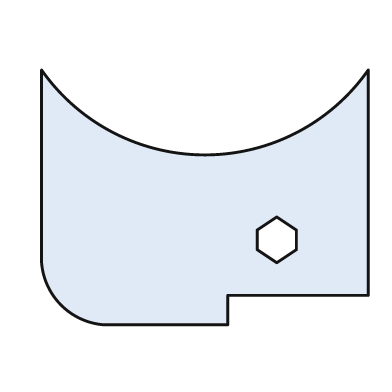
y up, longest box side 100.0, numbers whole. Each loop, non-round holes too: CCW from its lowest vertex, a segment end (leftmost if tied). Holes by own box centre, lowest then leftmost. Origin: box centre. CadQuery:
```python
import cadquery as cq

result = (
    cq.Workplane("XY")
    .moveTo(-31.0, -39.0)
    .lineTo(7.0, -39.0)
    .lineTo(7.0, -30.0)
    .lineTo(50.0, -30.0)
    .lineTo(50.0, 39.0)
    .threePointArc((0.0, 13.0), (-50.0, 39.0))
    .lineTo(-50.0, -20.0)
    .threePointArc((-44.0, -33.0), (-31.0, -39.0))
    .close()
    .moveTo(22.0, -20.0)
    .lineTo(28.0, -16.0)
    .lineTo(28.0, -10.0)
    .lineTo(22.0, -6.0)
    .lineTo(16.0, -10.0)
    .lineTo(16.0, -16.0)
    .close()
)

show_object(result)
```